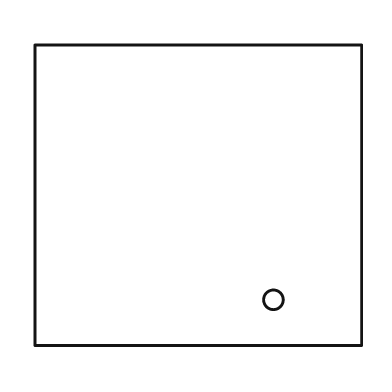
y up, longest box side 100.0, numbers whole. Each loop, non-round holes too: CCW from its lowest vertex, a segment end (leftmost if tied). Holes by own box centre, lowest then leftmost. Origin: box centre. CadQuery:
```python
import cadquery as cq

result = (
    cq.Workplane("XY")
    .moveTo(-50.0, -46.0)
    .lineTo(50.0, -46.0)
    .lineTo(50.0, 46.0)
    .lineTo(-50.0, 46.0)
    .close()
    .moveTo(23.0, -32.0)
    .circle(3.0)
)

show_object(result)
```